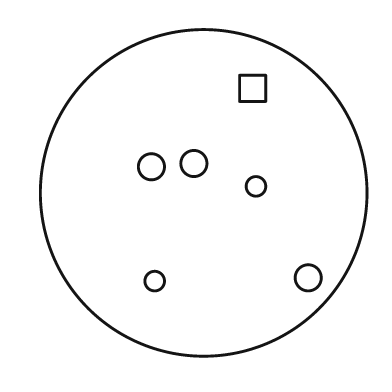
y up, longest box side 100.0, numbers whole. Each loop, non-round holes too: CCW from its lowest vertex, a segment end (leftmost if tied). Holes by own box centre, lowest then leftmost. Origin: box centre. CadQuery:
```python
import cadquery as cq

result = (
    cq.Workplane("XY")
    .moveTo(0.0, 0.0)
    .circle(50.0)
    .moveTo(-15.0, -27.0)
    .circle(3.0)
    .moveTo(32.0, -26.0)
    .circle(4.0)
    .moveTo(16.0, 2.0)
    .circle(3.0)
    .moveTo(-16.0, 8.0)
    .circle(4.0)
    .moveTo(-3.0, 9.0)
    .circle(4.0)
    .moveTo(11.0, 28.0)
    .lineTo(19.0, 28.0)
    .lineTo(19.0, 36.0)
    .lineTo(11.0, 36.0)
    .close()
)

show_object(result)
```